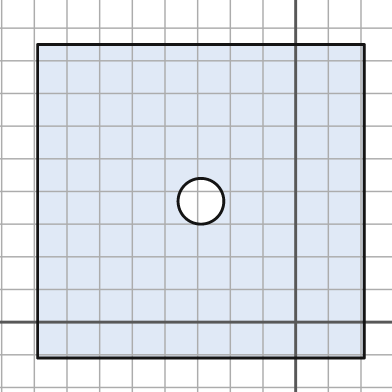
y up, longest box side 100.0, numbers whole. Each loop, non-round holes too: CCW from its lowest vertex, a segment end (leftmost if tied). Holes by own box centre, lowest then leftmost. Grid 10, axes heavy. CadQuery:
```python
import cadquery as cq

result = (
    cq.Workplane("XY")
    .moveTo(-79.0, -11.0)
    .lineTo(21.0, -11.0)
    .lineTo(21.0, 85.0)
    .lineTo(-79.0, 85.0)
    .close()
    .moveTo(-29.0, 37.0)
    .circle(7.0)
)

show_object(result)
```